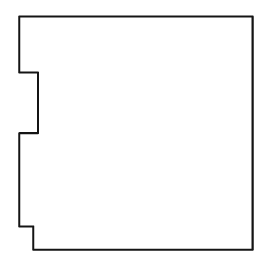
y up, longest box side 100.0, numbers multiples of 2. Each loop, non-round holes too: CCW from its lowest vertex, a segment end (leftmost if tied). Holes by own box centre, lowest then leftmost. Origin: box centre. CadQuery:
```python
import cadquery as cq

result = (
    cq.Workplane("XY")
    .moveTo(-44.0, -50.0)
    .lineTo(50.0, -50.0)
    .lineTo(50.0, 50.0)
    .lineTo(-50.0, 50.0)
    .lineTo(-50.0, 26.0)
    .lineTo(-42.0, 26.0)
    .lineTo(-42.0, 0.0)
    .lineTo(-50.0, 0.0)
    .lineTo(-50.0, -40.0)
    .lineTo(-44.0, -40.0)
    .close()
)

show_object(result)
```